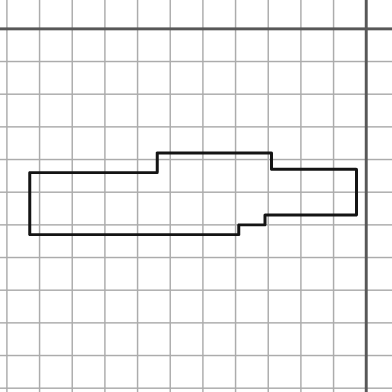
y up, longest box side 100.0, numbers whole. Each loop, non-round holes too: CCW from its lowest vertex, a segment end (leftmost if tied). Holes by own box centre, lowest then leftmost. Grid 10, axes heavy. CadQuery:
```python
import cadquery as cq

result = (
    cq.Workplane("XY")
    .moveTo(-103.0, -63.0)
    .lineTo(-39.0, -63.0)
    .lineTo(-39.0, -60.0)
    .lineTo(-31.0, -60.0)
    .lineTo(-31.0, -57.0)
    .lineTo(-3.0, -57.0)
    .lineTo(-3.0, -43.0)
    .lineTo(-29.0, -43.0)
    .lineTo(-29.0, -38.0)
    .lineTo(-64.0, -38.0)
    .lineTo(-64.0, -44.0)
    .lineTo(-103.0, -44.0)
    .close()
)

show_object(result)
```